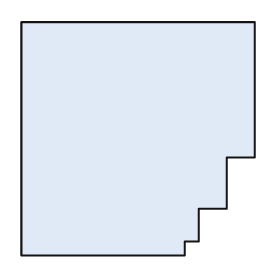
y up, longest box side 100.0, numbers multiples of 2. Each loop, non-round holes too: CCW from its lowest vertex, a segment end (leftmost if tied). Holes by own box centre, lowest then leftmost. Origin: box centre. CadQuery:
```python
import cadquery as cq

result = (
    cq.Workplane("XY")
    .moveTo(-50.0, -50.0)
    .lineTo(20.0, -50.0)
    .lineTo(20.0, -44.0)
    .lineTo(26.0, -44.0)
    .lineTo(26.0, -30.0)
    .lineTo(38.0, -30.0)
    .lineTo(38.0, -8.0)
    .lineTo(50.0, -8.0)
    .lineTo(50.0, 50.0)
    .lineTo(-50.0, 50.0)
    .close()
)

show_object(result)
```